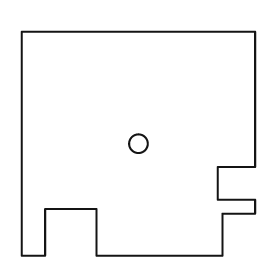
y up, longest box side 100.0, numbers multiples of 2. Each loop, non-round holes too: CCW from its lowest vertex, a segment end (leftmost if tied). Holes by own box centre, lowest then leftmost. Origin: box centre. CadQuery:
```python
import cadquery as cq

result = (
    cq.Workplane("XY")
    .moveTo(-50.0, -48.0)
    .lineTo(-40.0, -48.0)
    .lineTo(-40.0, -28.0)
    .lineTo(-18.0, -28.0)
    .lineTo(-18.0, -48.0)
    .lineTo(36.0, -48.0)
    .lineTo(36.0, -30.0)
    .lineTo(50.0, -30.0)
    .lineTo(50.0, -24.0)
    .lineTo(34.0, -24.0)
    .lineTo(34.0, -10.0)
    .lineTo(50.0, -10.0)
    .lineTo(50.0, 48.0)
    .lineTo(-50.0, 48.0)
    .close()
    .moveTo(0.0, 0.0)
    .circle(4.0)
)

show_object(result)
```